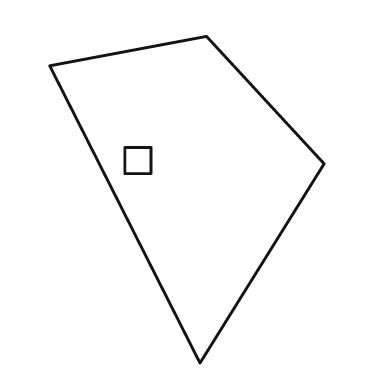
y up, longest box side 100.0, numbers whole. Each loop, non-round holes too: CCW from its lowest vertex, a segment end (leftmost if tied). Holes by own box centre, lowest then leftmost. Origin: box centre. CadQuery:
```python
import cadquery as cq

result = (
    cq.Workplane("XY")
    .moveTo(4.0, -50.0)
    .lineTo(42.0, 11.0)
    .lineTo(6.0, 50.0)
    .lineTo(-42.0, 41.0)
    .close()
    .moveTo(-19.0, 8.0)
    .lineTo(-11.0, 8.0)
    .lineTo(-11.0, 16.0)
    .lineTo(-19.0, 16.0)
    .close()
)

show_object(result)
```